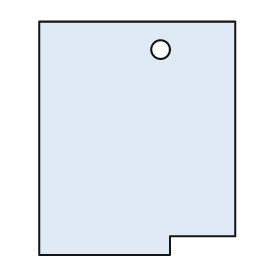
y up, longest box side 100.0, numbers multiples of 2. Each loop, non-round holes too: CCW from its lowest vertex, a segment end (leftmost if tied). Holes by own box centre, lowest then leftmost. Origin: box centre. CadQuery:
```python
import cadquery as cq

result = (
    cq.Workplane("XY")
    .moveTo(-42.0, -50.0)
    .lineTo(14.0, -50.0)
    .lineTo(14.0, -42.0)
    .lineTo(42.0, -42.0)
    .lineTo(42.0, 50.0)
    .lineTo(-42.0, 50.0)
    .close()
    .moveTo(10.0, 38.0)
    .circle(4.0)
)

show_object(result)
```